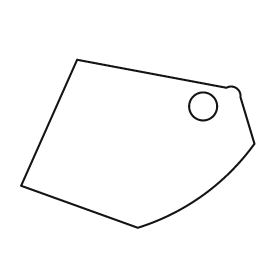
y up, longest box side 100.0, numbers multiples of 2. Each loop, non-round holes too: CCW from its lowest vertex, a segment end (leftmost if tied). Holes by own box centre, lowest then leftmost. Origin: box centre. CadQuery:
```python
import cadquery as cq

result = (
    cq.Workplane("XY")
    .moveTo(0.0, -36.0)
    .threePointArc((28.0, -22.0), (50.0, 0.0))
    .lineTo(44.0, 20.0)
    .threePointArc((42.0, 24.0), (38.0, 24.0))
    .lineTo(-26.0, 36.0)
    .lineTo(-50.0, -18.0)
    .close()
    .moveTo(28.0, 16.0)
    .circle(6.0)
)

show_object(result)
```